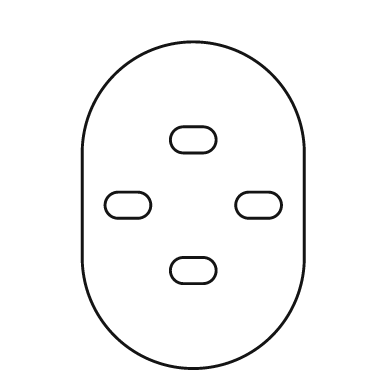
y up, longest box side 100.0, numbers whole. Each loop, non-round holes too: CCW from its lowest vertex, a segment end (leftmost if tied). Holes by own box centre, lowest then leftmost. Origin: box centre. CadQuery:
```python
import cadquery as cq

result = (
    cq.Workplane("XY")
    .moveTo(-34.0, -16.0)
    .threePointArc((0.0, -50.0), (34.0, -16.0))
    .lineTo(34.0, 16.0)
    .threePointArc((0.0, 50.0), (-34.0, 16.0))
    .close()
    .moveTo(-3.0, -24.0)
    .lineTo(3.0, -24.0)
    .threePointArc((7.0, -20.0), (3.0, -16.0))
    .lineTo(-3.0, -16.0)
    .threePointArc((-7.0, -20.0), (-3.0, -24.0))
    .close()
    .moveTo(-23.0, -4.0)
    .lineTo(-17.0, -4.0)
    .threePointArc((-13.0, 0.0), (-17.0, 4.0))
    .lineTo(-23.0, 4.0)
    .threePointArc((-27.0, 0.0), (-23.0, -4.0))
    .close()
    .moveTo(17.0, -4.0)
    .lineTo(23.0, -4.0)
    .threePointArc((27.0, 0.0), (23.0, 4.0))
    .lineTo(17.0, 4.0)
    .threePointArc((13.0, 0.0), (17.0, -4.0))
    .close()
    .moveTo(-3.0, 16.0)
    .lineTo(3.0, 16.0)
    .threePointArc((7.0, 20.0), (3.0, 24.0))
    .lineTo(-3.0, 24.0)
    .threePointArc((-7.0, 20.0), (-3.0, 16.0))
    .close()
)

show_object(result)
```